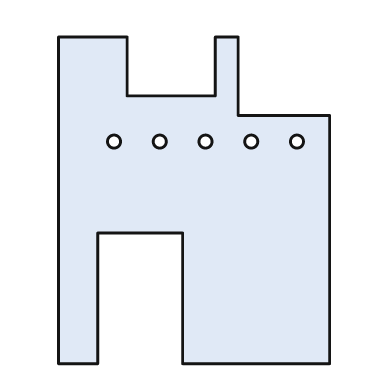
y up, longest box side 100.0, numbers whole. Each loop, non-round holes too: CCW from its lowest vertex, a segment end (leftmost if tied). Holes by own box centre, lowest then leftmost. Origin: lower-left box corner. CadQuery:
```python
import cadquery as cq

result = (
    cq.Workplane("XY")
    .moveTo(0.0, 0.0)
    .lineTo(12.0, 0.0)
    .lineTo(12.0, 40.0)
    .lineTo(38.0, 40.0)
    .lineTo(38.0, 0.0)
    .lineTo(83.0, 0.0)
    .lineTo(83.0, 76.0)
    .lineTo(55.0, 76.0)
    .lineTo(55.0, 100.0)
    .lineTo(48.0, 100.0)
    .lineTo(48.0, 82.0)
    .lineTo(21.0, 82.0)
    .lineTo(21.0, 100.0)
    .lineTo(0.0, 100.0)
    .close()
    .moveTo(17.0, 68.0)
    .circle(2.0)
    .moveTo(31.0, 68.0)
    .circle(2.0)
    .moveTo(45.0, 68.0)
    .circle(2.0)
    .moveTo(59.0, 68.0)
    .circle(2.0)
    .moveTo(73.0, 68.0)
    .circle(2.0)
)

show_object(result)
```